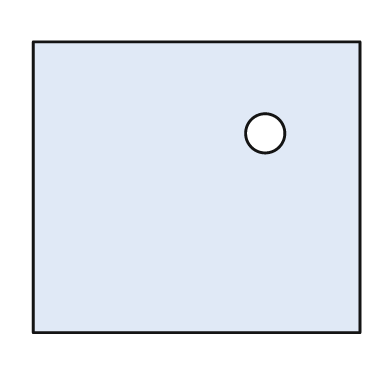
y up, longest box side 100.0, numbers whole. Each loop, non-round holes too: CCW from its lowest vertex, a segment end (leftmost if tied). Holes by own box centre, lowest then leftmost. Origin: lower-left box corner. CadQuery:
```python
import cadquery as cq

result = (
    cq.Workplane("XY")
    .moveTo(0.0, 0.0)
    .lineTo(100.0, 0.0)
    .lineTo(100.0, 89.0)
    .lineTo(0.0, 89.0)
    .close()
    .moveTo(71.0, 61.0)
    .circle(6.0)
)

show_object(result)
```